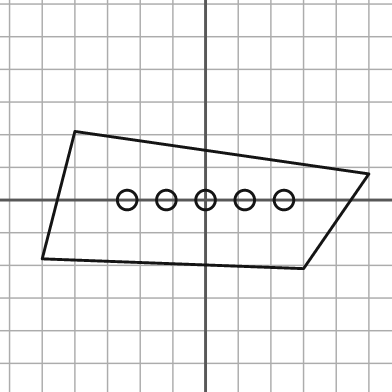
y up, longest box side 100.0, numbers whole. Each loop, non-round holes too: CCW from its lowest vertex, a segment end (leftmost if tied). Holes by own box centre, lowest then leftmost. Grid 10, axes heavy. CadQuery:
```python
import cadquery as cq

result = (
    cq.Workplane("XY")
    .moveTo(30.0, -21.0)
    .lineTo(50.0, 8.0)
    .lineTo(-40.0, 21.0)
    .lineTo(-50.0, -18.0)
    .close()
    .moveTo(-24.0, 0.0)
    .circle(3.0)
    .moveTo(-12.0, 0.0)
    .circle(3.0)
    .moveTo(0.0, 0.0)
    .circle(3.0)
    .moveTo(12.0, 0.0)
    .circle(3.0)
    .moveTo(24.0, 0.0)
    .circle(3.0)
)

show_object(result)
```